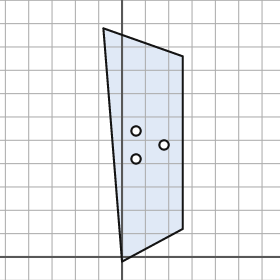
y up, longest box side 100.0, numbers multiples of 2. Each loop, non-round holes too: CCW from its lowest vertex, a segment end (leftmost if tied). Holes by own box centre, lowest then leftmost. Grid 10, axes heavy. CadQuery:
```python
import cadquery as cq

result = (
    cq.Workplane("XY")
    .moveTo(0.0, -2.0)
    .lineTo(26.0, 12.0)
    .lineTo(26.0, 86.0)
    .lineTo(-8.0, 98.0)
    .close()
    .moveTo(6.0, 42.0)
    .circle(2.0)
    .moveTo(18.0, 48.0)
    .circle(2.0)
    .moveTo(6.0, 54.0)
    .circle(2.0)
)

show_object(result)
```